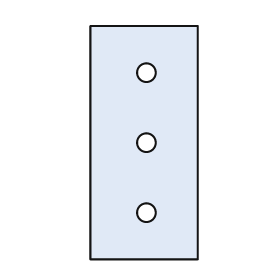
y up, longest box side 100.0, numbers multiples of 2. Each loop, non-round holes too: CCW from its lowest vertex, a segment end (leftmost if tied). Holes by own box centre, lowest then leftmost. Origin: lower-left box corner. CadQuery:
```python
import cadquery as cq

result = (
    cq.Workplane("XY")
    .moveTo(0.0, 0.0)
    .lineTo(46.0, 0.0)
    .lineTo(46.0, 100.0)
    .lineTo(0.0, 100.0)
    .close()
    .moveTo(24.0, 20.0)
    .circle(4.0)
    .moveTo(24.0, 50.0)
    .circle(4.0)
    .moveTo(24.0, 80.0)
    .circle(4.0)
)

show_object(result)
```